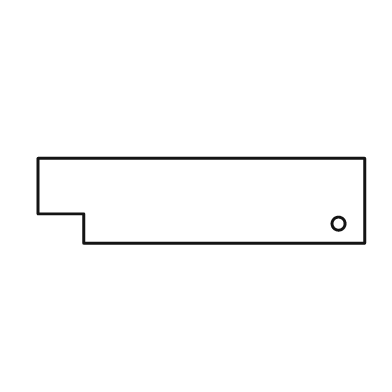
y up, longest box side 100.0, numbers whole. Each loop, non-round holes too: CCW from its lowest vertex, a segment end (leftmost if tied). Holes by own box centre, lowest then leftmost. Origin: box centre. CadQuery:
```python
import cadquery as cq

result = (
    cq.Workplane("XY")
    .moveTo(-36.0, -13.0)
    .lineTo(50.0, -13.0)
    .lineTo(50.0, 13.0)
    .lineTo(-50.0, 13.0)
    .lineTo(-50.0, -4.0)
    .lineTo(-36.0, -4.0)
    .close()
    .moveTo(42.0, -7.0)
    .circle(2.0)
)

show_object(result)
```